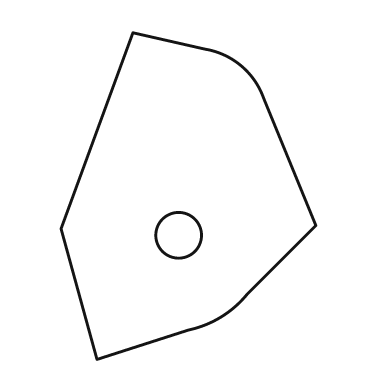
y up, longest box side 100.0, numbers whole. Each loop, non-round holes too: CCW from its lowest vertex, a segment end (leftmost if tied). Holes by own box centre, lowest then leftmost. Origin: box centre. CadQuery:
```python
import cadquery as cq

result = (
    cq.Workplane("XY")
    .moveTo(-28.0, -50.0)
    .lineTo(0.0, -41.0)
    .threePointArc((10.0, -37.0), (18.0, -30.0))
    .lineTo(39.0, -9.0)
    .lineTo(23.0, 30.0)
    .threePointArc((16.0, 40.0), (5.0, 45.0))
    .lineTo(-17.0, 50.0)
    .lineTo(-39.0, -10.0)
    .close()
    .moveTo(-3.0, -12.0)
    .circle(7.0)
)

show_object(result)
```